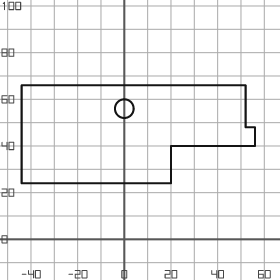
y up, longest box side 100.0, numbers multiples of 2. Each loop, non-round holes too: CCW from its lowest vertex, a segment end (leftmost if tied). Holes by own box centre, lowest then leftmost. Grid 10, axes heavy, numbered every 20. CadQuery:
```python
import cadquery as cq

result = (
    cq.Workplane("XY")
    .moveTo(-44.0, 24.0)
    .lineTo(20.0, 24.0)
    .lineTo(20.0, 40.0)
    .lineTo(56.0, 40.0)
    .lineTo(56.0, 48.0)
    .lineTo(52.0, 48.0)
    .lineTo(52.0, 66.0)
    .lineTo(-44.0, 66.0)
    .close()
    .moveTo(0.0, 56.0)
    .circle(4.0)
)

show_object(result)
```